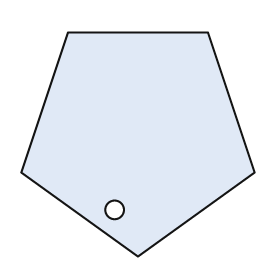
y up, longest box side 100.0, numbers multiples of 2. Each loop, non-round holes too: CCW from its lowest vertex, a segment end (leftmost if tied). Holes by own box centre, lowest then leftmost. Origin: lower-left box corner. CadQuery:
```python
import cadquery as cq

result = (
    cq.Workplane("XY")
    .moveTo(50.0, 0.0)
    .lineTo(100.0, 36.0)
    .lineTo(80.0, 96.0)
    .lineTo(20.0, 96.0)
    .lineTo(0.0, 36.0)
    .close()
    .moveTo(40.0, 20.0)
    .circle(4.0)
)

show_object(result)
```